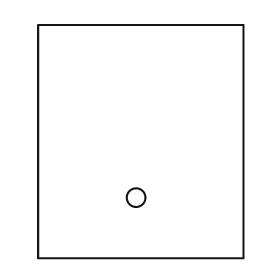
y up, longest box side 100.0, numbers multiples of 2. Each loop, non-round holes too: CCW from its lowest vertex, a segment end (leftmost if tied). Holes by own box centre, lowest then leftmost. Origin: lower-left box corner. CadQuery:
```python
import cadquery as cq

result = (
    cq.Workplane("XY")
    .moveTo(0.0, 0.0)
    .lineTo(88.0, 0.0)
    .lineTo(88.0, 100.0)
    .lineTo(0.0, 100.0)
    .close()
    .moveTo(42.0, 26.0)
    .circle(4.0)
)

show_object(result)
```